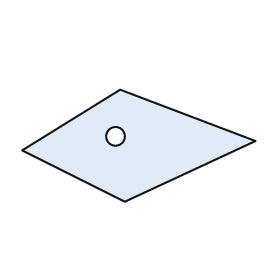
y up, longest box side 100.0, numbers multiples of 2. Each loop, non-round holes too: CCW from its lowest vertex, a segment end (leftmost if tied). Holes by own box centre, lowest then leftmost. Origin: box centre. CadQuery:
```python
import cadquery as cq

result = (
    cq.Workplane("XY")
    .moveTo(-6.0, -24.0)
    .lineTo(50.0, 2.0)
    .lineTo(-8.0, 24.0)
    .lineTo(-50.0, -2.0)
    .close()
    .moveTo(-10.0, 4.0)
    .circle(4.0)
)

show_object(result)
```